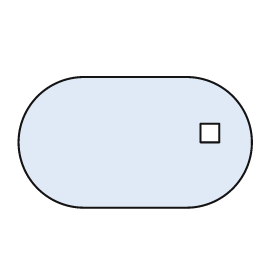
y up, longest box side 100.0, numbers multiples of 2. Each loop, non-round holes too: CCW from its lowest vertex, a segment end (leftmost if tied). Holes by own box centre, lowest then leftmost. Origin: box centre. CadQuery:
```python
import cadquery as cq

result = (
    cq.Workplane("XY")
    .moveTo(-22.0, -28.0)
    .lineTo(22.0, -28.0)
    .threePointArc((50.0, 0.0), (22.0, 28.0))
    .lineTo(-22.0, 28.0)
    .threePointArc((-50.0, 0.0), (-22.0, -28.0))
    .close()
    .moveTo(28.0, 0.0)
    .lineTo(36.0, 0.0)
    .lineTo(36.0, 8.0)
    .lineTo(28.0, 8.0)
    .close()
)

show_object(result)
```